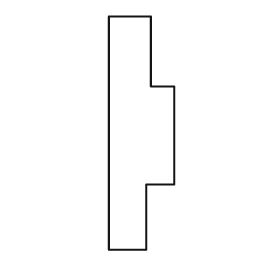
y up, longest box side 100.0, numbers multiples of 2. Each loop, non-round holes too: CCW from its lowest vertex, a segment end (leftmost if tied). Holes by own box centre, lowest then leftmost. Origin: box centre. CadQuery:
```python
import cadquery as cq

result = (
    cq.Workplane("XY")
    .moveTo(-14.0, -50.0)
    .lineTo(2.0, -50.0)
    .lineTo(2.0, -22.0)
    .lineTo(14.0, -22.0)
    .lineTo(14.0, 20.0)
    .lineTo(4.0, 20.0)
    .lineTo(4.0, 50.0)
    .lineTo(-14.0, 50.0)
    .close()
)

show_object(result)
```